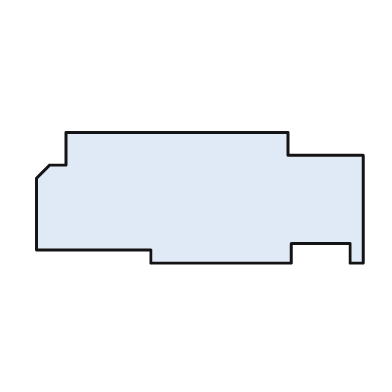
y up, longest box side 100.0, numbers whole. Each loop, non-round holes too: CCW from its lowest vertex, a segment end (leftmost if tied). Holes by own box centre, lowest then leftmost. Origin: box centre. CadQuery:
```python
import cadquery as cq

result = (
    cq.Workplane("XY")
    .moveTo(-15.0, -20.0)
    .lineTo(28.0, -20.0)
    .lineTo(28.0, -14.0)
    .lineTo(46.0, -14.0)
    .lineTo(46.0, -20.0)
    .lineTo(50.0, -20.0)
    .lineTo(50.0, 13.0)
    .lineTo(27.0, 13.0)
    .lineTo(27.0, 20.0)
    .lineTo(-41.0, 20.0)
    .lineTo(-41.0, 10.0)
    .lineTo(-46.0, 10.0)
    .lineTo(-50.0, 6.0)
    .lineTo(-50.0, -16.0)
    .lineTo(-15.0, -16.0)
    .close()
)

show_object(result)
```